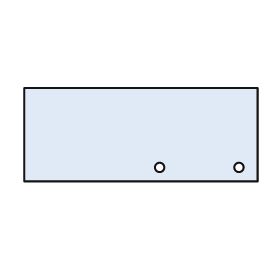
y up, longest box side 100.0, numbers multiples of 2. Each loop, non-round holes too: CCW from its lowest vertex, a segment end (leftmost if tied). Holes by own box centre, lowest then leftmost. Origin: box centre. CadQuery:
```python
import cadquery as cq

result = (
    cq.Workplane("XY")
    .moveTo(-50.0, -20.0)
    .lineTo(50.0, -20.0)
    .lineTo(50.0, 20.0)
    .lineTo(-50.0, 20.0)
    .close()
    .moveTo(8.0, -14.0)
    .circle(2.0)
    .moveTo(42.0, -14.0)
    .circle(2.0)
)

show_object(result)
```